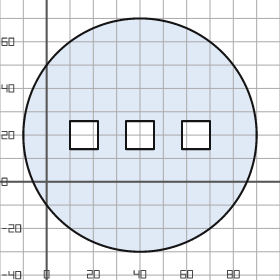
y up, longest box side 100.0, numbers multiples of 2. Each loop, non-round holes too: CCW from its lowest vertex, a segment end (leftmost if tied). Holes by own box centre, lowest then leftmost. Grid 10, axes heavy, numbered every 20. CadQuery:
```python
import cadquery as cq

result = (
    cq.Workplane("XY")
    .moveTo(40.0, 20.0)
    .circle(50.0)
    .moveTo(10.0, 14.0)
    .lineTo(22.0, 14.0)
    .lineTo(22.0, 26.0)
    .lineTo(10.0, 26.0)
    .close()
    .moveTo(34.0, 14.0)
    .lineTo(46.0, 14.0)
    .lineTo(46.0, 26.0)
    .lineTo(34.0, 26.0)
    .close()
    .moveTo(58.0, 14.0)
    .lineTo(70.0, 14.0)
    .lineTo(70.0, 26.0)
    .lineTo(58.0, 26.0)
    .close()
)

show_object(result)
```